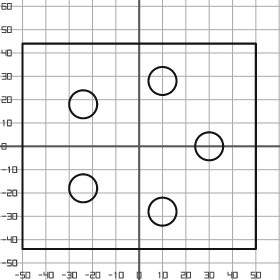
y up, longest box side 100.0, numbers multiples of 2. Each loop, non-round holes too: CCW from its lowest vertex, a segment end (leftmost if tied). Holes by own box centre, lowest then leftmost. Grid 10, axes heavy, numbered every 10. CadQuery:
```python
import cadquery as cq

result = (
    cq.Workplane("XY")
    .moveTo(-50.0, -44.0)
    .lineTo(50.0, -44.0)
    .lineTo(50.0, 44.0)
    .lineTo(-50.0, 44.0)
    .close()
    .moveTo(10.0, -28.0)
    .circle(6.0)
    .moveTo(-24.0, -18.0)
    .circle(6.0)
    .moveTo(30.0, 0.0)
    .circle(6.0)
    .moveTo(-24.0, 18.0)
    .circle(6.0)
    .moveTo(10.0, 28.0)
    .circle(6.0)
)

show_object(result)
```